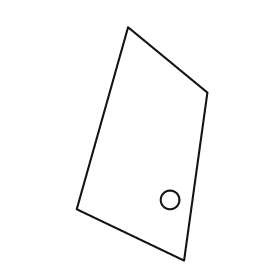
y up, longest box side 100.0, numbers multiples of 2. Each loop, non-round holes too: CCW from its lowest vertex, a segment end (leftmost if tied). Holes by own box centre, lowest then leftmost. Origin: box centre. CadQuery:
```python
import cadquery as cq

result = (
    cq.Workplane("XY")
    .moveTo(18.0, -50.0)
    .lineTo(28.0, 22.0)
    .lineTo(-6.0, 50.0)
    .lineTo(-28.0, -28.0)
    .close()
    .moveTo(12.0, -24.0)
    .circle(4.0)
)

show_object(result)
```